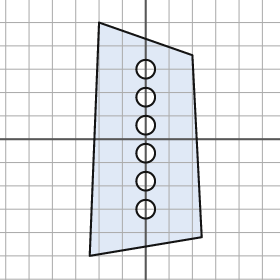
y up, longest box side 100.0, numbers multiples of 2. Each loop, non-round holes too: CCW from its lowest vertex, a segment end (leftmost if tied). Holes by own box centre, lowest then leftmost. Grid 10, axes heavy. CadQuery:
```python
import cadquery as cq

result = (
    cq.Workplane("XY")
    .moveTo(-24.0, -50.0)
    .lineTo(24.0, -42.0)
    .lineTo(20.0, 36.0)
    .lineTo(-20.0, 50.0)
    .close()
    .moveTo(0.0, -30.0)
    .circle(4.0)
    .moveTo(0.0, -18.0)
    .circle(4.0)
    .moveTo(0.0, -6.0)
    .circle(4.0)
    .moveTo(0.0, 6.0)
    .circle(4.0)
    .moveTo(0.0, 18.0)
    .circle(4.0)
    .moveTo(0.0, 30.0)
    .circle(4.0)
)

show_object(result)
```